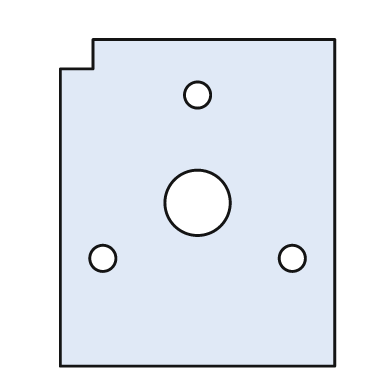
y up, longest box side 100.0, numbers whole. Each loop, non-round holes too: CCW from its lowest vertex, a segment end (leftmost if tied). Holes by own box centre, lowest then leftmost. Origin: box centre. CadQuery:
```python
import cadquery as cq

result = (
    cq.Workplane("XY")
    .moveTo(-42.0, -50.0)
    .lineTo(42.0, -50.0)
    .lineTo(42.0, 50.0)
    .lineTo(-32.0, 50.0)
    .lineTo(-32.0, 41.0)
    .lineTo(-42.0, 41.0)
    .close()
    .moveTo(-29.0, -17.0)
    .circle(4.0)
    .moveTo(29.0, -17.0)
    .circle(4.0)
    .moveTo(0.0, 0.0)
    .circle(10.0)
    .moveTo(0.0, 33.0)
    .circle(4.0)
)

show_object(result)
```